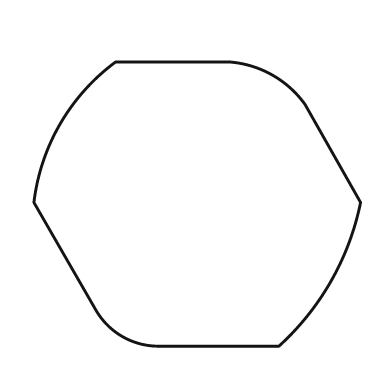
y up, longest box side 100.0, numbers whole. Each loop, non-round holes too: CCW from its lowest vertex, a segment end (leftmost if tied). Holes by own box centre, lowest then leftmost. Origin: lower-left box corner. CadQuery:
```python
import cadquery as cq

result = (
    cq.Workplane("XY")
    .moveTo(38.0, 0.0)
    .lineTo(75.0, 0.0)
    .threePointArc((91.0, 20.0), (100.0, 44.0))
    .lineTo(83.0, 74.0)
    .threePointArc((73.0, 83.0), (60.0, 87.0))
    .lineTo(25.0, 87.0)
    .threePointArc((8.0, 68.0), (0.0, 44.0))
    .lineTo(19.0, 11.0)
    .threePointArc((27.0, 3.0), (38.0, 0.0))
    .close()
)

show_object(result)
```